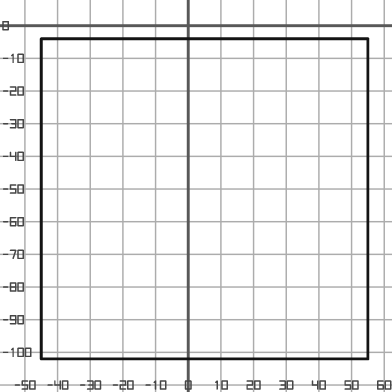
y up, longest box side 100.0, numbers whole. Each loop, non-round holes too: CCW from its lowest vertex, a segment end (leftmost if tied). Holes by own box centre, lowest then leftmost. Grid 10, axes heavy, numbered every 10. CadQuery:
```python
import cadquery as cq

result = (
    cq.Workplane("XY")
    .moveTo(-45.0, -102.0)
    .lineTo(55.0, -102.0)
    .lineTo(55.0, -4.0)
    .lineTo(-45.0, -4.0)
    .close()
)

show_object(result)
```